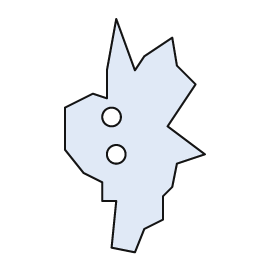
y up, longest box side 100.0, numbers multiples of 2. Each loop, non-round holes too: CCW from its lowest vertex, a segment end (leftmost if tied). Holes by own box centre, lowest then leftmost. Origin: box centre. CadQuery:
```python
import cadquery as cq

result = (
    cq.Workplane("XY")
    .moveTo(0.0, -50.0)
    .lineTo(4.0, -40.0)
    .lineTo(12.0, -36.0)
    .lineTo(12.0, -26.0)
    .lineTo(16.0, -22.0)
    .lineTo(18.0, -12.0)
    .lineTo(30.0, -8.0)
    .lineTo(14.0, 4.0)
    .lineTo(26.0, 22.0)
    .lineTo(18.0, 30.0)
    .lineTo(16.0, 42.0)
    .lineTo(4.0, 34.0)
    .lineTo(0.0, 28.0)
    .lineTo(-8.0, 50.0)
    .lineTo(-12.0, 28.0)
    .lineTo(-12.0, 16.0)
    .lineTo(-18.0, 18.0)
    .lineTo(-30.0, 12.0)
    .lineTo(-30.0, -6.0)
    .lineTo(-22.0, -16.0)
    .lineTo(-14.0, -20.0)
    .lineTo(-14.0, -28.0)
    .lineTo(-8.0, -28.0)
    .lineTo(-10.0, -48.0)
    .close()
    .moveTo(-8.0, -8.0)
    .circle(4.0)
    .moveTo(-10.0, 8.0)
    .circle(4.0)
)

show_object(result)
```